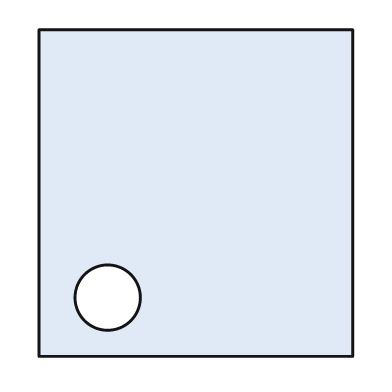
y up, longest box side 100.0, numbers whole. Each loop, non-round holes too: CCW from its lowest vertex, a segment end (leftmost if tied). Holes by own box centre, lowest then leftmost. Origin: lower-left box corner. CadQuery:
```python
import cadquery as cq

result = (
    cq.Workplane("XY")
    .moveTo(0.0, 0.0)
    .lineTo(96.0, 0.0)
    .lineTo(96.0, 100.0)
    .lineTo(0.0, 100.0)
    .close()
    .moveTo(21.0, 18.0)
    .circle(10.0)
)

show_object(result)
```